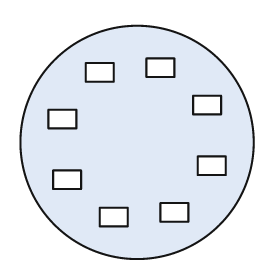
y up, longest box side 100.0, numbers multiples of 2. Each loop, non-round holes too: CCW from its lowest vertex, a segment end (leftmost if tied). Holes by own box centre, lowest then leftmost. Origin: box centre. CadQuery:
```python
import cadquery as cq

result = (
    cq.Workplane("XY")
    .moveTo(0.0, 0.0)
    .circle(50.0)
    .moveTo(-16.0, -36.0)
    .lineTo(-4.0, -36.0)
    .lineTo(-4.0, -28.0)
    .lineTo(-16.0, -28.0)
    .close()
    .moveTo(10.0, -34.0)
    .lineTo(22.0, -34.0)
    .lineTo(22.0, -26.0)
    .lineTo(10.0, -26.0)
    .close()
    .moveTo(-36.0, -20.0)
    .lineTo(-24.0, -20.0)
    .lineTo(-24.0, -12.0)
    .lineTo(-36.0, -12.0)
    .close()
    .moveTo(26.0, -14.0)
    .lineTo(38.0, -14.0)
    .lineTo(38.0, -6.0)
    .lineTo(26.0, -6.0)
    .close()
    .moveTo(-38.0, 6.0)
    .lineTo(-26.0, 6.0)
    .lineTo(-26.0, 14.0)
    .lineTo(-38.0, 14.0)
    .close()
    .moveTo(24.0, 12.0)
    .lineTo(36.0, 12.0)
    .lineTo(36.0, 20.0)
    .lineTo(24.0, 20.0)
    .close()
    .moveTo(-22.0, 26.0)
    .lineTo(-10.0, 26.0)
    .lineTo(-10.0, 34.0)
    .lineTo(-22.0, 34.0)
    .close()
    .moveTo(4.0, 28.0)
    .lineTo(16.0, 28.0)
    .lineTo(16.0, 36.0)
    .lineTo(4.0, 36.0)
    .close()
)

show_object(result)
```